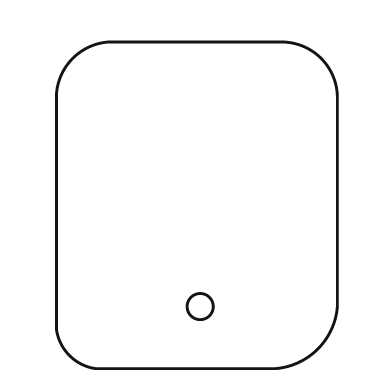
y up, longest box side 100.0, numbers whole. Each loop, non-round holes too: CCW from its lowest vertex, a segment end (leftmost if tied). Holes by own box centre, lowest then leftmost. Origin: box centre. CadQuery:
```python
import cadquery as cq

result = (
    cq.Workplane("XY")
    .moveTo(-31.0, -50.0)
    .lineTo(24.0, -50.0)
    .threePointArc((37.0, -44.0), (43.0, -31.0))
    .lineTo(43.0, 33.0)
    .threePointArc((38.0, 45.0), (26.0, 50.0))
    .lineTo(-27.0, 50.0)
    .threePointArc((-38.0, 45.0), (-43.0, 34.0))
    .lineTo(-43.0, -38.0)
    .threePointArc((-39.0, -46.0), (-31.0, -50.0))
    .close()
    .moveTo(1.0, -31.0)
    .circle(4.0)
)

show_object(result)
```